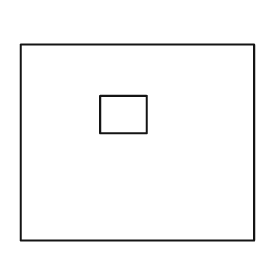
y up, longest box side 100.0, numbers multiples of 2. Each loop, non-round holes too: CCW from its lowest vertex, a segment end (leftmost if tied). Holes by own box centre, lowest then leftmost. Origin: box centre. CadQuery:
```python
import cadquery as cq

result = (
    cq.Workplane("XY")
    .moveTo(-50.0, -42.0)
    .lineTo(50.0, -42.0)
    .lineTo(50.0, 42.0)
    .lineTo(-50.0, 42.0)
    .close()
    .moveTo(-16.0, 4.0)
    .lineTo(4.0, 4.0)
    .lineTo(4.0, 20.0)
    .lineTo(-16.0, 20.0)
    .close()
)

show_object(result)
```